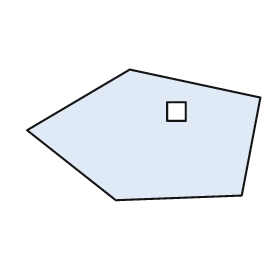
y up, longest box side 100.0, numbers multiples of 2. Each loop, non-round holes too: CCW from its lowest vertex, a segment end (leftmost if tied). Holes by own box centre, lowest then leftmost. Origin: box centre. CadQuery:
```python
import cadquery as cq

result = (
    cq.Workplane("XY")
    .moveTo(-12.0, -28.0)
    .lineTo(42.0, -26.0)
    .lineTo(50.0, 16.0)
    .lineTo(-6.0, 28.0)
    .lineTo(-50.0, 2.0)
    .close()
    .moveTo(10.0, 6.0)
    .lineTo(18.0, 6.0)
    .lineTo(18.0, 14.0)
    .lineTo(10.0, 14.0)
    .close()
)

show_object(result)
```